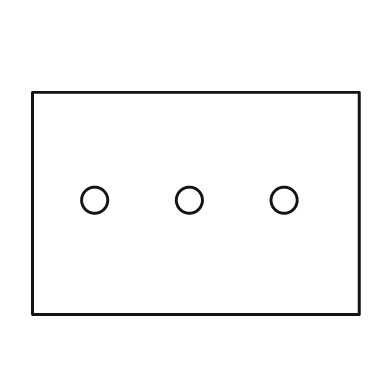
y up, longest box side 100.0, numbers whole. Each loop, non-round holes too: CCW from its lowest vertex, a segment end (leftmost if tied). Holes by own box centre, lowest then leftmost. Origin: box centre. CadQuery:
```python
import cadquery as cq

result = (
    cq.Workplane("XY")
    .moveTo(-50.0, -34.0)
    .lineTo(50.0, -34.0)
    .lineTo(50.0, 34.0)
    .lineTo(-50.0, 34.0)
    .close()
    .moveTo(-31.0, 1.0)
    .circle(4.0)
    .moveTo(-2.0, 1.0)
    .circle(4.0)
    .moveTo(27.0, 1.0)
    .circle(4.0)
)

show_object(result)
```